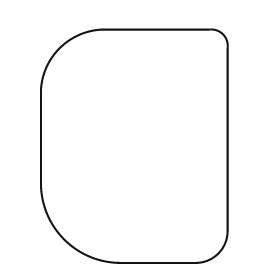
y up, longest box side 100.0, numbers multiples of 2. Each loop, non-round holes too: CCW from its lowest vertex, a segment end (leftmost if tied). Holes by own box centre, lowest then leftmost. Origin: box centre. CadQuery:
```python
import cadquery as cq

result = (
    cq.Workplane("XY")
    .moveTo(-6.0, -50.0)
    .lineTo(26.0, -50.0)
    .threePointArc((36.0, -46.0), (40.0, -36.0))
    .lineTo(40.0, 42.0)
    .threePointArc((38.0, 48.0), (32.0, 50.0))
    .lineTo(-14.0, 50.0)
    .threePointArc((-32.0, 42.0), (-40.0, 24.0))
    .lineTo(-40.0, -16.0)
    .threePointArc((-30.0, -40.0), (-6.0, -50.0))
    .close()
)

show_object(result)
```